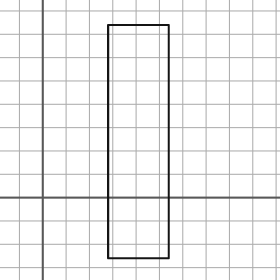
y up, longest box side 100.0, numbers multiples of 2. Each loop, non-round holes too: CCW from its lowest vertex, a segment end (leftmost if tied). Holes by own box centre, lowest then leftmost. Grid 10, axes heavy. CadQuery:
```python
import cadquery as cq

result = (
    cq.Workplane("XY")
    .moveTo(28.0, -26.0)
    .lineTo(54.0, -26.0)
    .lineTo(54.0, 74.0)
    .lineTo(28.0, 74.0)
    .close()
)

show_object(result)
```